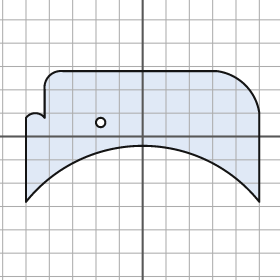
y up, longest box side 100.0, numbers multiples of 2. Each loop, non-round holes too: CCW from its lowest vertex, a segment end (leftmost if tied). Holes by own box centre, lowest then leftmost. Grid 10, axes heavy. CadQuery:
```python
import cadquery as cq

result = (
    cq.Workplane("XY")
    .moveTo(-50.0, -28.0)
    .threePointArc((0.0, -4.0), (50.0, -28.0))
    .lineTo(50.0, 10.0)
    .threePointArc((44.0, 22.0), (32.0, 28.0))
    .lineTo(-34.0, 28.0)
    .threePointArc((-40.0, 26.0), (-42.0, 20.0))
    .lineTo(-42.0, 8.0)
    .threePointArc((-46.0, 10.0), (-50.0, 8.0))
    .close()
    .moveTo(-18.0, 6.0)
    .circle(2.0)
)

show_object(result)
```